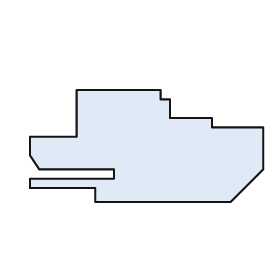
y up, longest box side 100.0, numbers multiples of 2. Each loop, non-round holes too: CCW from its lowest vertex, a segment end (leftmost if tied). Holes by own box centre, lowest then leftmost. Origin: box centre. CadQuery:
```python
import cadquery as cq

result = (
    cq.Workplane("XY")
    .moveTo(-22.0, -24.0)
    .lineTo(36.0, -24.0)
    .lineTo(50.0, -10.0)
    .lineTo(50.0, 8.0)
    .lineTo(28.0, 8.0)
    .lineTo(28.0, 12.0)
    .lineTo(10.0, 12.0)
    .lineTo(10.0, 20.0)
    .lineTo(6.0, 20.0)
    .lineTo(6.0, 24.0)
    .lineTo(-30.0, 24.0)
    .lineTo(-30.0, 4.0)
    .lineTo(-50.0, 4.0)
    .lineTo(-50.0, -4.0)
    .lineTo(-46.0, -10.0)
    .lineTo(-14.0, -10.0)
    .lineTo(-14.0, -14.0)
    .lineTo(-50.0, -14.0)
    .lineTo(-50.0, -18.0)
    .lineTo(-22.0, -18.0)
    .close()
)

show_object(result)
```